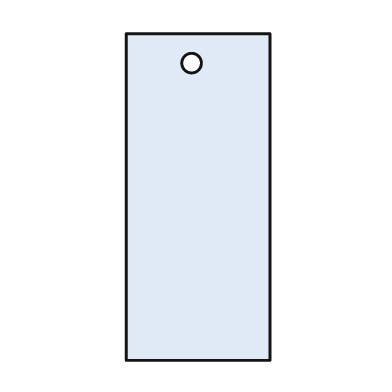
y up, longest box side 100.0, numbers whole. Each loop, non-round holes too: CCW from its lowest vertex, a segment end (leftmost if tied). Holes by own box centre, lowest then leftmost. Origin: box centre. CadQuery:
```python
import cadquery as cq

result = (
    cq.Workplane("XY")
    .moveTo(-22.0, -50.0)
    .lineTo(22.0, -50.0)
    .lineTo(22.0, 50.0)
    .lineTo(-22.0, 50.0)
    .close()
    .moveTo(-2.0, 41.0)
    .circle(3.0)
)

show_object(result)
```